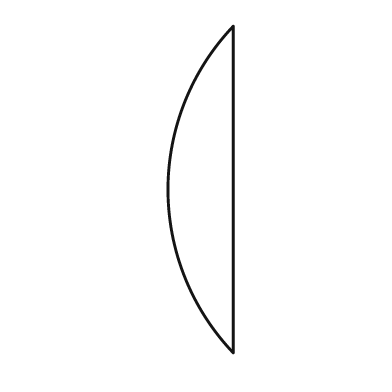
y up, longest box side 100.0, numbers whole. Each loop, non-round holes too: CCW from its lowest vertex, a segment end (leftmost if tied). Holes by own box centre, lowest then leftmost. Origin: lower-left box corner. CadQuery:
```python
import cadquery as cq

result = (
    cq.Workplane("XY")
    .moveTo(20.0, 0.0)
    .lineTo(20.0, 100.0)
    .threePointArc((0.0, 50.0), (20.0, 0.0))
    .close()
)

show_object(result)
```